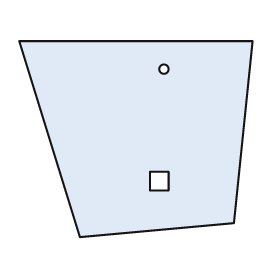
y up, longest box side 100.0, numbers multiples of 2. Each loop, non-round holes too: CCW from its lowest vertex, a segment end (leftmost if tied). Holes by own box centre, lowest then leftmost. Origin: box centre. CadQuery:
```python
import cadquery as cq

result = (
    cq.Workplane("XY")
    .moveTo(-24.0, -42.0)
    .lineTo(42.0, -36.0)
    .lineTo(50.0, 42.0)
    .lineTo(-50.0, 42.0)
    .close()
    .moveTo(6.0, -22.0)
    .lineTo(14.0, -22.0)
    .lineTo(14.0, -14.0)
    .lineTo(6.0, -14.0)
    .close()
    .moveTo(12.0, 30.0)
    .circle(2.0)
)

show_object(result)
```